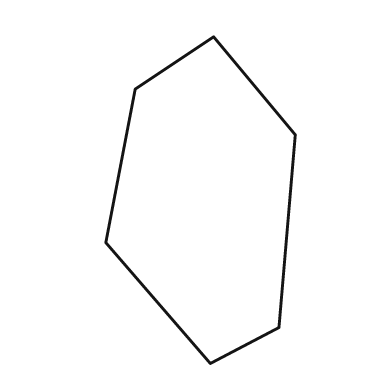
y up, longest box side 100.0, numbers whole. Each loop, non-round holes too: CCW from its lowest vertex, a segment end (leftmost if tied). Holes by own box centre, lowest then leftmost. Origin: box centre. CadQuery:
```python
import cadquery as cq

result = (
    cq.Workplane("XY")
    .moveTo(3.0, -50.0)
    .lineTo(24.0, -39.0)
    .lineTo(29.0, 20.0)
    .lineTo(4.0, 50.0)
    .lineTo(-20.0, 34.0)
    .lineTo(-29.0, -13.0)
    .close()
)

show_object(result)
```